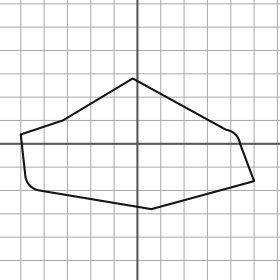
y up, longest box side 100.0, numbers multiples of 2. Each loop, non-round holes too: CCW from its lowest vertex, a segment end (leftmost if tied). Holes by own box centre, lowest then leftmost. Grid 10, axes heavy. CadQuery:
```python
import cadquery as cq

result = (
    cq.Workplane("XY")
    .moveTo(6.0, -28.0)
    .lineTo(50.0, -16.0)
    .lineTo(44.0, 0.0)
    .threePointArc((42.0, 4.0), (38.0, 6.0))
    .lineTo(-2.0, 28.0)
    .lineTo(-32.0, 10.0)
    .lineTo(-50.0, 4.0)
    .lineTo(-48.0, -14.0)
    .threePointArc((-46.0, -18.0), (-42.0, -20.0))
    .close()
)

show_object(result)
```